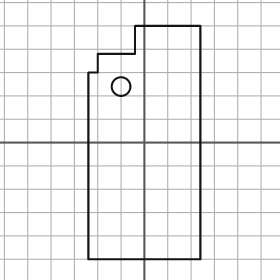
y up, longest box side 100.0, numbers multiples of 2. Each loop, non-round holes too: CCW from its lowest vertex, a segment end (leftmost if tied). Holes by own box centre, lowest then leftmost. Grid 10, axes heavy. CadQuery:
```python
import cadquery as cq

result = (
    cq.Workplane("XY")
    .moveTo(-24.0, -50.0)
    .lineTo(24.0, -50.0)
    .lineTo(24.0, 50.0)
    .lineTo(-4.0, 50.0)
    .lineTo(-4.0, 38.0)
    .lineTo(-20.0, 38.0)
    .lineTo(-20.0, 30.0)
    .lineTo(-24.0, 30.0)
    .close()
    .moveTo(-10.0, 24.0)
    .circle(4.0)
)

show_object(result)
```